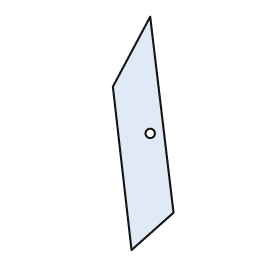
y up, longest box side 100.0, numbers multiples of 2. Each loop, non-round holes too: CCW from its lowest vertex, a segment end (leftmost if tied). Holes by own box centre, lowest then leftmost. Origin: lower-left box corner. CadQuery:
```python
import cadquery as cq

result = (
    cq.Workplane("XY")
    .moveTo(8.0, 0.0)
    .lineTo(26.0, 16.0)
    .lineTo(16.0, 100.0)
    .lineTo(0.0, 70.0)
    .close()
    .moveTo(16.0, 50.0)
    .circle(2.0)
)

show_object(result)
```